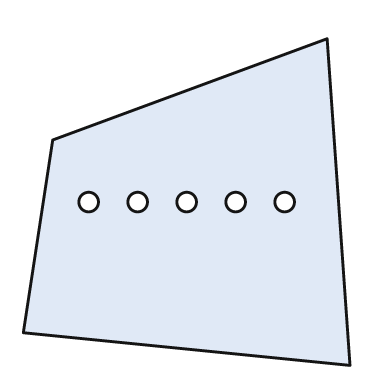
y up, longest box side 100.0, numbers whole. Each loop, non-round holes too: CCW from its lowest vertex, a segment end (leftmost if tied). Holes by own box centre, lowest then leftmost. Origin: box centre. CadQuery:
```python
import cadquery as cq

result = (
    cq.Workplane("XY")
    .moveTo(50.0, -50.0)
    .lineTo(43.0, 50.0)
    .lineTo(-41.0, 19.0)
    .lineTo(-50.0, -40.0)
    .close()
    .moveTo(-30.0, 0.0)
    .circle(3.0)
    .moveTo(-15.0, 0.0)
    .circle(3.0)
    .moveTo(0.0, 0.0)
    .circle(3.0)
    .moveTo(15.0, 0.0)
    .circle(3.0)
    .moveTo(30.0, 0.0)
    .circle(3.0)
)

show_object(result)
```